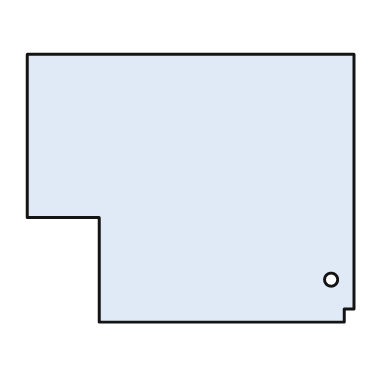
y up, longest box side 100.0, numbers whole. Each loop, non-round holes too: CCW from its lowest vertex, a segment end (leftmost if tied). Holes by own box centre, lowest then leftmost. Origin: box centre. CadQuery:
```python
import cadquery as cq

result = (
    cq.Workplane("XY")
    .moveTo(-28.0, -41.0)
    .lineTo(47.0, -41.0)
    .lineTo(47.0, -37.0)
    .lineTo(50.0, -37.0)
    .lineTo(50.0, 41.0)
    .lineTo(-50.0, 41.0)
    .lineTo(-50.0, -9.0)
    .lineTo(-28.0, -9.0)
    .close()
    .moveTo(43.0, -28.0)
    .circle(2.0)
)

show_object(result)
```